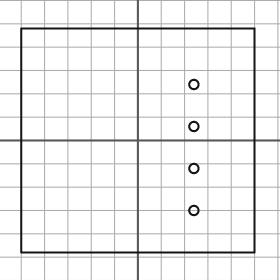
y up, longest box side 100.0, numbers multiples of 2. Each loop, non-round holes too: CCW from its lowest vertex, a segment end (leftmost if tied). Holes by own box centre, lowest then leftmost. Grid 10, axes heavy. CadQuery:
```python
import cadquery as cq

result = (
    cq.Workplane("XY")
    .moveTo(-50.0, -48.0)
    .lineTo(50.0, -48.0)
    .lineTo(50.0, 48.0)
    .lineTo(-50.0, 48.0)
    .close()
    .moveTo(24.0, -30.0)
    .circle(2.0)
    .moveTo(24.0, -12.0)
    .circle(2.0)
    .moveTo(24.0, 6.0)
    .circle(2.0)
    .moveTo(24.0, 24.0)
    .circle(2.0)
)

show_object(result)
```